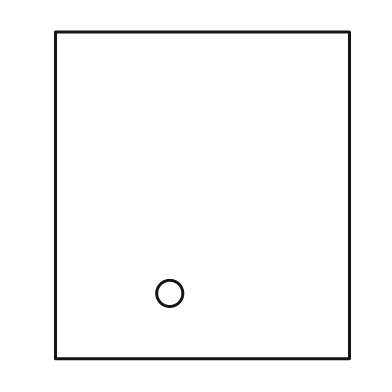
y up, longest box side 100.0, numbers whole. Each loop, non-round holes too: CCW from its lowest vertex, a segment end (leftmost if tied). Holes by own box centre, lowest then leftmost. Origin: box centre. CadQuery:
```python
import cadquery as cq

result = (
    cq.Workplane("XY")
    .moveTo(-45.0, -50.0)
    .lineTo(45.0, -50.0)
    .lineTo(45.0, 50.0)
    .lineTo(-45.0, 50.0)
    .close()
    .moveTo(-10.0, -30.0)
    .circle(4.0)
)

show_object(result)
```